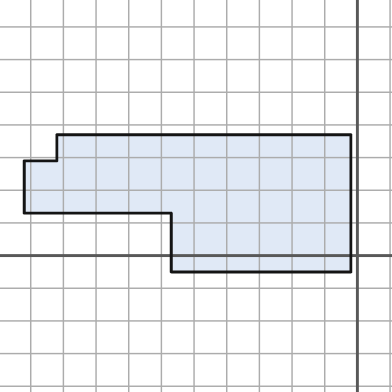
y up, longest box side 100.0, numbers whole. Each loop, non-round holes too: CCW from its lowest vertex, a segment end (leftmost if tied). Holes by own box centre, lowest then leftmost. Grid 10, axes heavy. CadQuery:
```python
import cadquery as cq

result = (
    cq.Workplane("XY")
    .moveTo(-57.0, -5.0)
    .lineTo(-2.0, -5.0)
    .lineTo(-2.0, 37.0)
    .lineTo(-92.0, 37.0)
    .lineTo(-92.0, 29.0)
    .lineTo(-102.0, 29.0)
    .lineTo(-102.0, 13.0)
    .lineTo(-57.0, 13.0)
    .close()
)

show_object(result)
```